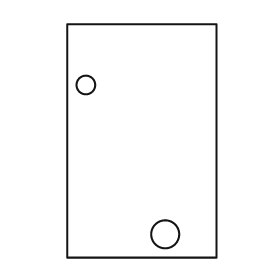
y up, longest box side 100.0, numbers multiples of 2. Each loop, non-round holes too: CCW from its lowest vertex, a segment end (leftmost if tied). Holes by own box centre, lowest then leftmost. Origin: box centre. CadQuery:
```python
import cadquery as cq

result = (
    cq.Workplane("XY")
    .moveTo(-32.0, -50.0)
    .lineTo(32.0, -50.0)
    .lineTo(32.0, 50.0)
    .lineTo(-32.0, 50.0)
    .close()
    .moveTo(10.0, -40.0)
    .circle(6.0)
    .moveTo(-24.0, 24.0)
    .circle(4.0)
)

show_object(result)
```